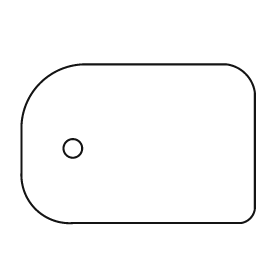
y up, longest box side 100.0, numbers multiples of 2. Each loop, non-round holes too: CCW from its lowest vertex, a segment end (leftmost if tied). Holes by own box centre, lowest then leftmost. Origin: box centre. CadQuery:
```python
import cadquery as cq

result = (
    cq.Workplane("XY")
    .moveTo(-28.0, -34.0)
    .lineTo(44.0, -34.0)
    .threePointArc((48.0, -32.0), (50.0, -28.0))
    .lineTo(50.0, 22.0)
    .threePointArc((46.0, 30.0), (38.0, 34.0))
    .lineTo(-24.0, 34.0)
    .threePointArc((-42.0, 26.0), (-50.0, 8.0))
    .lineTo(-50.0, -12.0)
    .threePointArc((-44.0, -28.0), (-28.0, -34.0))
    .close()
    .moveTo(-28.0, -2.0)
    .circle(4.0)
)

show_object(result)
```